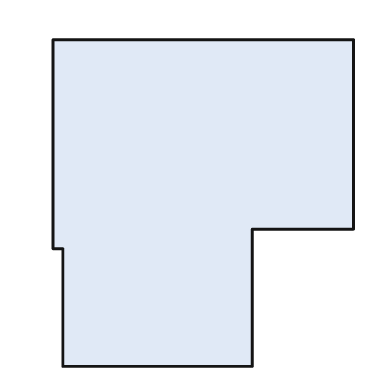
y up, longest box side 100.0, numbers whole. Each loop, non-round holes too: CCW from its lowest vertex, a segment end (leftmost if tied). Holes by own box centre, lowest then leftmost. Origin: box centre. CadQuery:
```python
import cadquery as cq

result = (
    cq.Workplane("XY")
    .moveTo(-43.0, -50.0)
    .lineTo(15.0, -50.0)
    .lineTo(15.0, -8.0)
    .lineTo(46.0, -8.0)
    .lineTo(46.0, 50.0)
    .lineTo(-46.0, 50.0)
    .lineTo(-46.0, -14.0)
    .lineTo(-43.0, -14.0)
    .close()
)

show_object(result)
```